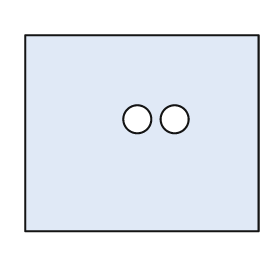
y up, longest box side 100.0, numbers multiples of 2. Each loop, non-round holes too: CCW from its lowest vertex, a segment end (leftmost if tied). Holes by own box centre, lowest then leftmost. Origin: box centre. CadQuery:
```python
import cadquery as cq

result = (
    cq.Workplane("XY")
    .moveTo(-50.0, -42.0)
    .lineTo(50.0, -42.0)
    .lineTo(50.0, 42.0)
    .lineTo(-50.0, 42.0)
    .close()
    .moveTo(-2.0, 6.0)
    .circle(6.0)
    .moveTo(14.0, 6.0)
    .circle(6.0)
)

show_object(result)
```